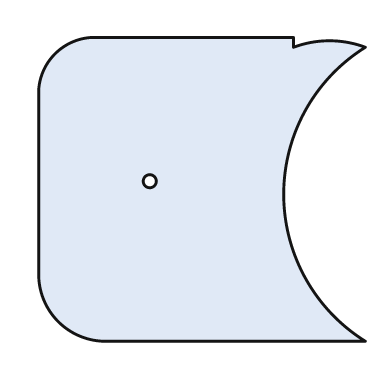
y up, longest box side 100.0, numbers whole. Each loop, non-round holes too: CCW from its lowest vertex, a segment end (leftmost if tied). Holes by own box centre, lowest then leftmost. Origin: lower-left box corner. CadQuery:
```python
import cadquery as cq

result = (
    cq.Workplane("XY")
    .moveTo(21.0, 0.0)
    .lineTo(100.0, 0.0)
    .threePointArc((75.0, 45.0), (100.0, 90.0))
    .threePointArc((89.0, 92.0), (78.0, 90.0))
    .lineTo(78.0, 93.0)
    .lineTo(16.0, 93.0)
    .threePointArc((5.0, 88.0), (0.0, 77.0))
    .lineTo(0.0, 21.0)
    .threePointArc((6.0, 6.0), (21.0, 0.0))
    .close()
    .moveTo(34.0, 49.0)
    .circle(2.0)
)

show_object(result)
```